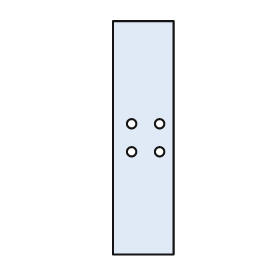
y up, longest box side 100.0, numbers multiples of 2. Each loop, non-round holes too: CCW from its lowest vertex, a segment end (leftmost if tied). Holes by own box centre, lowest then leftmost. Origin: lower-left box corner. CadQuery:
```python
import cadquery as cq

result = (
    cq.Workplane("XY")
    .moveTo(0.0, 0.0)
    .lineTo(26.0, 0.0)
    .lineTo(26.0, 100.0)
    .lineTo(0.0, 100.0)
    .close()
    .moveTo(8.0, 44.0)
    .circle(2.0)
    .moveTo(20.0, 44.0)
    .circle(2.0)
    .moveTo(8.0, 56.0)
    .circle(2.0)
    .moveTo(20.0, 56.0)
    .circle(2.0)
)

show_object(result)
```